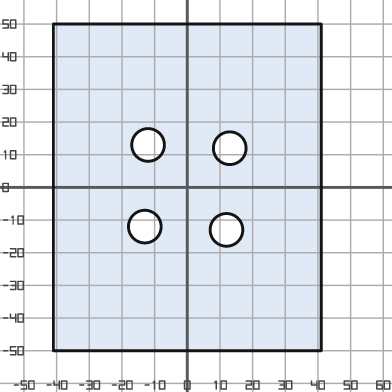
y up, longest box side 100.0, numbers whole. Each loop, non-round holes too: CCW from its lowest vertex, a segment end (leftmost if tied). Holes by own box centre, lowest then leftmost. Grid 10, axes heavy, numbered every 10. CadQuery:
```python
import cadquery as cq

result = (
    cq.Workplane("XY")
    .moveTo(-41.0, -50.0)
    .lineTo(41.0, -50.0)
    .lineTo(41.0, 50.0)
    .lineTo(-41.0, 50.0)
    .close()
    .moveTo(12.0, -13.0)
    .circle(5.0)
    .moveTo(-13.0, -12.0)
    .circle(5.0)
    .moveTo(13.0, 12.0)
    .circle(5.0)
    .moveTo(-12.0, 13.0)
    .circle(5.0)
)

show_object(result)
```